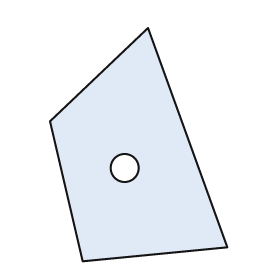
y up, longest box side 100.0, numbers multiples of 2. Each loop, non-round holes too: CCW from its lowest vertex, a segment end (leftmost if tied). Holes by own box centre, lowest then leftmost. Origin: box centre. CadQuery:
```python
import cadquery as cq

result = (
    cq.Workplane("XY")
    .moveTo(-24.0, -50.0)
    .lineTo(38.0, -44.0)
    .lineTo(4.0, 50.0)
    .lineTo(-38.0, 10.0)
    .close()
    .moveTo(-6.0, -10.0)
    .circle(6.0)
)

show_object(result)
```